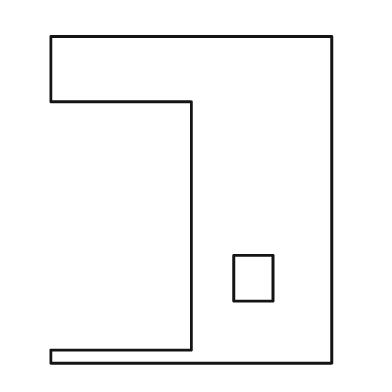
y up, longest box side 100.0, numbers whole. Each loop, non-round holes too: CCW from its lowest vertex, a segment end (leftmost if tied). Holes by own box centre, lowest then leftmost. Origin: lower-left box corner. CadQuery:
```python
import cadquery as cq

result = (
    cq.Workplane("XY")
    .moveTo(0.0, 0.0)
    .lineTo(86.0, 0.0)
    .lineTo(86.0, 100.0)
    .lineTo(0.0, 100.0)
    .lineTo(0.0, 80.0)
    .lineTo(43.0, 80.0)
    .lineTo(43.0, 4.0)
    .lineTo(0.0, 4.0)
    .close()
    .moveTo(56.0, 19.0)
    .lineTo(68.0, 19.0)
    .lineTo(68.0, 33.0)
    .lineTo(56.0, 33.0)
    .close()
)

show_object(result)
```